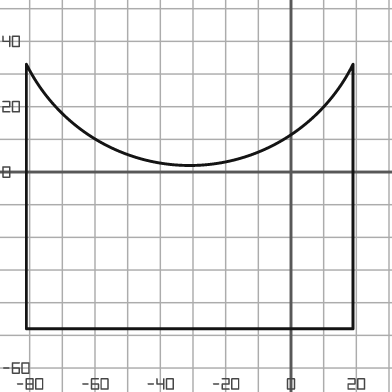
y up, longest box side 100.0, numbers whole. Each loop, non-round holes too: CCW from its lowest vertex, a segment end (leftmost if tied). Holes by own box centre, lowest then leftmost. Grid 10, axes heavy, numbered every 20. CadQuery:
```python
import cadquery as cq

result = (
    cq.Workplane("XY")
    .moveTo(-81.0, -48.0)
    .lineTo(19.0, -48.0)
    .lineTo(19.0, 33.0)
    .threePointArc((-31.0, 2.0), (-81.0, 33.0))
    .close()
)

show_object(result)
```